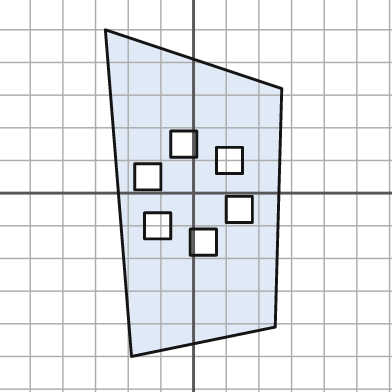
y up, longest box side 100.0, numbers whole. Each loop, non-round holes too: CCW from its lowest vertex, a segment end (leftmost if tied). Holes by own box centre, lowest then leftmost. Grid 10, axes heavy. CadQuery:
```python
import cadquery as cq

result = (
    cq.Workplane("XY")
    .moveTo(-19.0, -50.0)
    .lineTo(25.0, -41.0)
    .lineTo(27.0, 32.0)
    .lineTo(-27.0, 50.0)
    .close()
    .moveTo(-1.0, -19.0)
    .lineTo(7.0, -19.0)
    .lineTo(7.0, -11.0)
    .lineTo(-1.0, -11.0)
    .close()
    .moveTo(-15.0, -14.0)
    .lineTo(-7.0, -14.0)
    .lineTo(-7.0, -6.0)
    .lineTo(-15.0, -6.0)
    .close()
    .moveTo(10.0, -9.0)
    .lineTo(18.0, -9.0)
    .lineTo(18.0, -1.0)
    .lineTo(10.0, -1.0)
    .close()
    .moveTo(-18.0, 1.0)
    .lineTo(-10.0, 1.0)
    .lineTo(-10.0, 9.0)
    .lineTo(-18.0, 9.0)
    .close()
    .moveTo(7.0, 6.0)
    .lineTo(15.0, 6.0)
    .lineTo(15.0, 14.0)
    .lineTo(7.0, 14.0)
    .close()
    .moveTo(-7.0, 11.0)
    .lineTo(1.0, 11.0)
    .lineTo(1.0, 19.0)
    .lineTo(-7.0, 19.0)
    .close()
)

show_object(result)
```